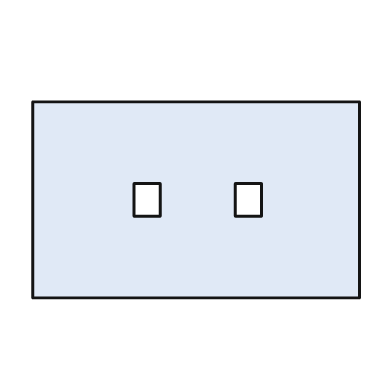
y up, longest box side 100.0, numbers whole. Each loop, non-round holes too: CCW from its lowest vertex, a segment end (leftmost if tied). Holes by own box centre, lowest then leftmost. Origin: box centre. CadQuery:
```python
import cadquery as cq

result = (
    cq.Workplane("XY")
    .moveTo(-50.0, -30.0)
    .lineTo(50.0, -30.0)
    .lineTo(50.0, 30.0)
    .lineTo(-50.0, 30.0)
    .close()
    .moveTo(-19.0, -5.0)
    .lineTo(-11.0, -5.0)
    .lineTo(-11.0, 5.0)
    .lineTo(-19.0, 5.0)
    .close()
    .moveTo(12.0, -5.0)
    .lineTo(20.0, -5.0)
    .lineTo(20.0, 5.0)
    .lineTo(12.0, 5.0)
    .close()
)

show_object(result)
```